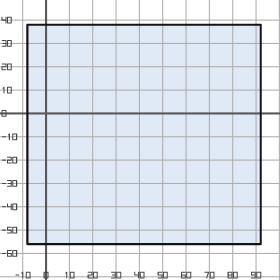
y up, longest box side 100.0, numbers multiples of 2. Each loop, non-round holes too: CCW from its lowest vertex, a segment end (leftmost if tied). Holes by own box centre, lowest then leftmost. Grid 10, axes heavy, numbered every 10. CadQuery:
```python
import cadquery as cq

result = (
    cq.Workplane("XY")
    .moveTo(-8.0, -56.0)
    .lineTo(92.0, -56.0)
    .lineTo(92.0, 38.0)
    .lineTo(-8.0, 38.0)
    .close()
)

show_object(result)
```